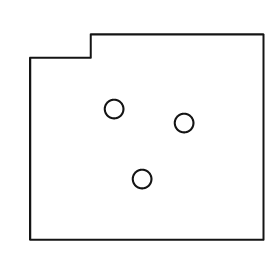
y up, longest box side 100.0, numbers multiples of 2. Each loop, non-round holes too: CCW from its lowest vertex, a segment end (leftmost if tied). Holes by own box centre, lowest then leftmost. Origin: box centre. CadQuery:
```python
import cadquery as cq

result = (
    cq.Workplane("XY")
    .moveTo(-50.0, -44.0)
    .lineTo(50.0, -44.0)
    .lineTo(50.0, 44.0)
    .lineTo(-24.0, 44.0)
    .lineTo(-24.0, 34.0)
    .lineTo(-50.0, 34.0)
    .close()
    .moveTo(-2.0, -18.0)
    .circle(4.0)
    .moveTo(16.0, 6.0)
    .circle(4.0)
    .moveTo(-14.0, 12.0)
    .circle(4.0)
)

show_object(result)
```